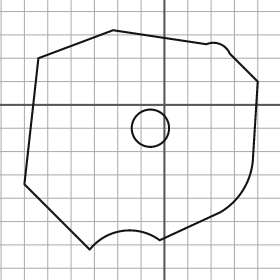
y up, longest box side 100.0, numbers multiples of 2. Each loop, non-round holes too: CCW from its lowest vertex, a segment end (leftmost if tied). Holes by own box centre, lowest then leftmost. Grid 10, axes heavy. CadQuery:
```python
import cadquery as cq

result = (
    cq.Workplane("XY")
    .moveTo(-32.0, -62.0)
    .threePointArc((-18.0, -54.0), (-2.0, -58.0))
    .lineTo(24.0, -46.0)
    .threePointArc((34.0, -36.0), (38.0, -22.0))
    .lineTo(40.0, 10.0)
    .lineTo(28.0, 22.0)
    .threePointArc((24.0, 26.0), (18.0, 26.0))
    .lineTo(-22.0, 32.0)
    .lineTo(-54.0, 20.0)
    .lineTo(-60.0, -34.0)
    .close()
    .moveTo(-6.0, -10.0)
    .circle(8.0)
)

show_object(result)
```